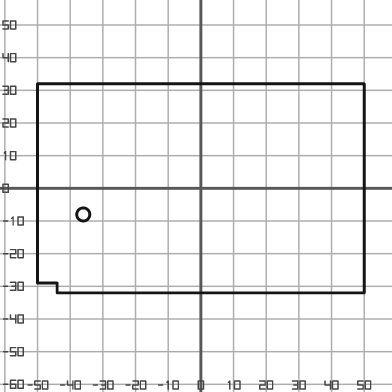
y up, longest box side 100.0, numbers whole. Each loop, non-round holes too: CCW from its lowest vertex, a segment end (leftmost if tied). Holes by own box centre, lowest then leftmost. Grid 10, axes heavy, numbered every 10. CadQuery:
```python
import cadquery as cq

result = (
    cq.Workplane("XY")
    .moveTo(-44.0, -32.0)
    .lineTo(50.0, -32.0)
    .lineTo(50.0, 32.0)
    .lineTo(-50.0, 32.0)
    .lineTo(-50.0, -29.0)
    .lineTo(-44.0, -29.0)
    .close()
    .moveTo(-36.0, -8.0)
    .circle(2.0)
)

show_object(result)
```